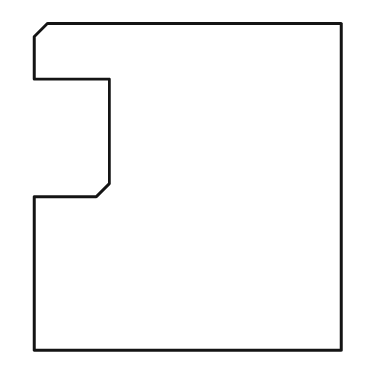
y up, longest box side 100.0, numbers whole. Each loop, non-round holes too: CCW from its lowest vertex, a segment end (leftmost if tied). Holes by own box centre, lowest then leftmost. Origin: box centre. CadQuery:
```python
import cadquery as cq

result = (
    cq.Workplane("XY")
    .moveTo(-47.0, -50.0)
    .lineTo(47.0, -50.0)
    .lineTo(47.0, 50.0)
    .lineTo(-43.0, 50.0)
    .lineTo(-47.0, 46.0)
    .lineTo(-47.0, 33.0)
    .lineTo(-24.0, 33.0)
    .lineTo(-24.0, 1.0)
    .lineTo(-28.0, -3.0)
    .lineTo(-47.0, -3.0)
    .close()
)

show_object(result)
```